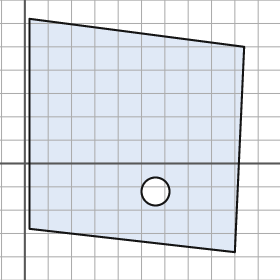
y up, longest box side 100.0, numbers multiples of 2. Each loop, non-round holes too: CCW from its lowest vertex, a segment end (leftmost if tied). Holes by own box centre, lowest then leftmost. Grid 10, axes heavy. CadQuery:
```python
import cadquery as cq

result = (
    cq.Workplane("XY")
    .moveTo(90.0, -38.0)
    .lineTo(94.0, 50.0)
    .lineTo(2.0, 62.0)
    .lineTo(2.0, -28.0)
    .close()
    .moveTo(56.0, -12.0)
    .circle(6.0)
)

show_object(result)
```